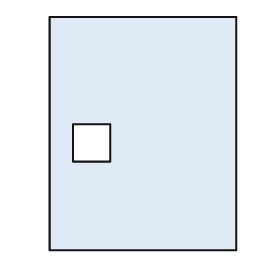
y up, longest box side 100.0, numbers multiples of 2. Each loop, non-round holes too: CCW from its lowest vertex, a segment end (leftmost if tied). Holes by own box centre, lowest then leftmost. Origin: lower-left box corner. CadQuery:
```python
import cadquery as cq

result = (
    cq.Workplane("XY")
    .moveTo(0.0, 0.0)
    .lineTo(80.0, 0.0)
    .lineTo(80.0, 100.0)
    .lineTo(0.0, 100.0)
    .close()
    .moveTo(10.0, 38.0)
    .lineTo(26.0, 38.0)
    .lineTo(26.0, 54.0)
    .lineTo(10.0, 54.0)
    .close()
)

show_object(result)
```